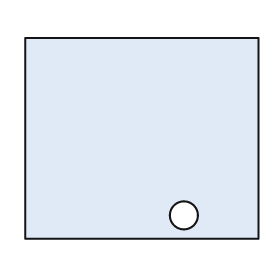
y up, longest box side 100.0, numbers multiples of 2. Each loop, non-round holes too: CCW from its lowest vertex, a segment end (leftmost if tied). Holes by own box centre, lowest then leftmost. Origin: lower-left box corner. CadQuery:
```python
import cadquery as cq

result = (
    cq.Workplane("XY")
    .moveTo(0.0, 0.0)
    .lineTo(100.0, 0.0)
    .lineTo(100.0, 86.0)
    .lineTo(0.0, 86.0)
    .close()
    .moveTo(68.0, 10.0)
    .circle(6.0)
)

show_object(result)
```